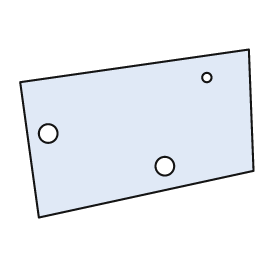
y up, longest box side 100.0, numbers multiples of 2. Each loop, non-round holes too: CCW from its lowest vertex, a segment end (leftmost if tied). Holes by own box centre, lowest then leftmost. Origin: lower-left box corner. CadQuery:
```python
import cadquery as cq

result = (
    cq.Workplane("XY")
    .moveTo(8.0, 0.0)
    .lineTo(100.0, 20.0)
    .lineTo(98.0, 72.0)
    .lineTo(0.0, 58.0)
    .close()
    .moveTo(62.0, 22.0)
    .circle(4.0)
    .moveTo(12.0, 36.0)
    .circle(4.0)
    .moveTo(80.0, 60.0)
    .circle(2.0)
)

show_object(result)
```